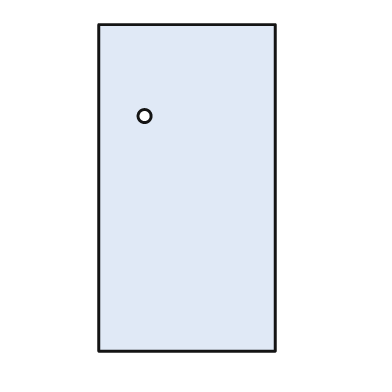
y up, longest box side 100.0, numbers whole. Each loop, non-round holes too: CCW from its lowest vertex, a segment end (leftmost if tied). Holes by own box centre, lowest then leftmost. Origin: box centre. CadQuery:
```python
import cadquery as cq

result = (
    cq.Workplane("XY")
    .moveTo(-27.0, -50.0)
    .lineTo(27.0, -50.0)
    .lineTo(27.0, 50.0)
    .lineTo(-27.0, 50.0)
    .close()
    .moveTo(-13.0, 22.0)
    .circle(2.0)
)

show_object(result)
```